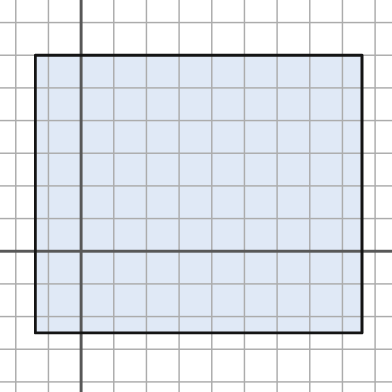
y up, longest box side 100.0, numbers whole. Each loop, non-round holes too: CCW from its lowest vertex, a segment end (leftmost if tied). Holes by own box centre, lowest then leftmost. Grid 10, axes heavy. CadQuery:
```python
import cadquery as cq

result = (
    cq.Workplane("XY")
    .moveTo(-14.0, -25.0)
    .lineTo(86.0, -25.0)
    .lineTo(86.0, 60.0)
    .lineTo(-14.0, 60.0)
    .close()
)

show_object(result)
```